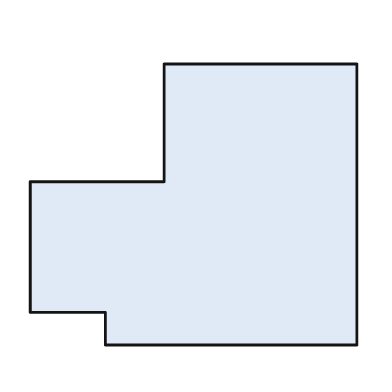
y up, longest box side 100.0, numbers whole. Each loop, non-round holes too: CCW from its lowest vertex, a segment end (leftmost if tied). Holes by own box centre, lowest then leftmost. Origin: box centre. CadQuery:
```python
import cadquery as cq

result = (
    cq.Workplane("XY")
    .moveTo(-27.0, -43.0)
    .lineTo(50.0, -43.0)
    .lineTo(50.0, 43.0)
    .lineTo(-9.0, 43.0)
    .lineTo(-9.0, 7.0)
    .lineTo(-50.0, 7.0)
    .lineTo(-50.0, -33.0)
    .lineTo(-27.0, -33.0)
    .close()
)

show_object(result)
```